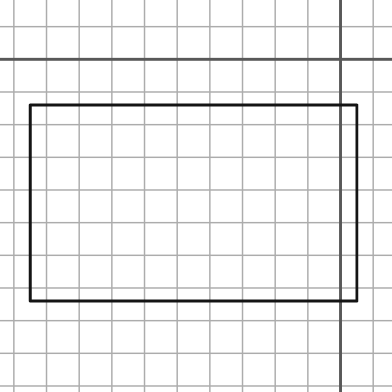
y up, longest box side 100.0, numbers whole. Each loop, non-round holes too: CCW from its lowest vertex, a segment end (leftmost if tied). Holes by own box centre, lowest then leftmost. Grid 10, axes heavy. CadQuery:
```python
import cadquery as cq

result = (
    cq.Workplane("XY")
    .moveTo(-95.0, -74.0)
    .lineTo(5.0, -74.0)
    .lineTo(5.0, -14.0)
    .lineTo(-95.0, -14.0)
    .close()
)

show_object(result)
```